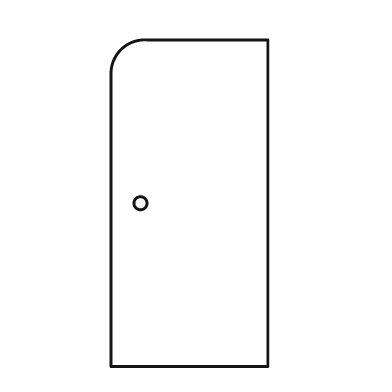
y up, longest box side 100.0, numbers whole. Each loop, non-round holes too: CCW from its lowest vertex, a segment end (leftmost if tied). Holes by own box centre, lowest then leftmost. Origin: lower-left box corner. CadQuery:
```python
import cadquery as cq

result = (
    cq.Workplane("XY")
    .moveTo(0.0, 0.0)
    .lineTo(48.0, 0.0)
    .lineTo(48.0, 100.0)
    .lineTo(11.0, 100.0)
    .threePointArc((3.0, 97.0), (0.0, 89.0))
    .close()
    .moveTo(9.0, 50.0)
    .circle(2.0)
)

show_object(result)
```